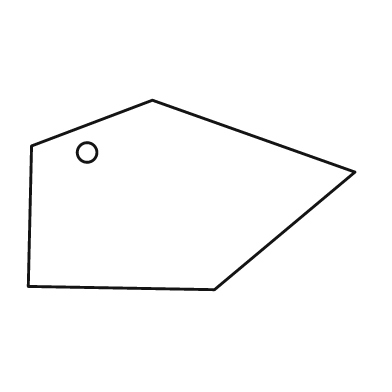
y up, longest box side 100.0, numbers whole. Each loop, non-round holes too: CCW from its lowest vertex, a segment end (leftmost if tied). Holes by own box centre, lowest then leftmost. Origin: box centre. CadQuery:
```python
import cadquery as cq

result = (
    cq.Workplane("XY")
    .moveTo(7.0, -29.0)
    .lineTo(50.0, 7.0)
    .lineTo(-12.0, 29.0)
    .lineTo(-49.0, 15.0)
    .lineTo(-50.0, -28.0)
    .close()
    .moveTo(-32.0, 13.0)
    .circle(3.0)
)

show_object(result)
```